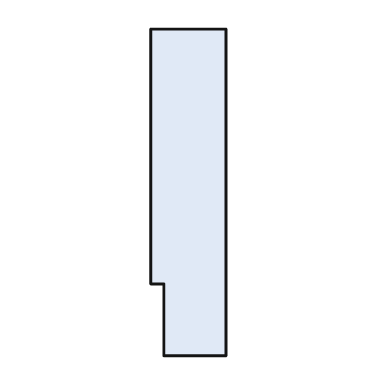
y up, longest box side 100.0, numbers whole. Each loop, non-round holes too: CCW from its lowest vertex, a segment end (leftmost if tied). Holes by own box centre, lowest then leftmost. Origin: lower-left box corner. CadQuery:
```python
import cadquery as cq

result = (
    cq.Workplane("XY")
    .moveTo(4.0, 0.0)
    .lineTo(23.0, 0.0)
    .lineTo(23.0, 100.0)
    .lineTo(0.0, 100.0)
    .lineTo(0.0, 22.0)
    .lineTo(4.0, 22.0)
    .close()
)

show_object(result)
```